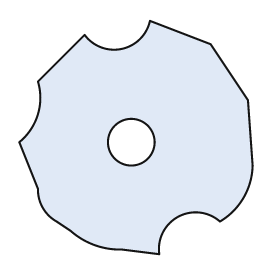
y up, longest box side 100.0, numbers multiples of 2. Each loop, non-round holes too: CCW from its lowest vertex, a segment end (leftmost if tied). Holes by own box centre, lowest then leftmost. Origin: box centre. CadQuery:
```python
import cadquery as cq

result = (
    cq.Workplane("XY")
    .moveTo(10.0, -50.0)
    .threePointArc((18.0, -34.0), (36.0, -36.0))
    .threePointArc((46.0, -26.0), (50.0, -12.0))
    .lineTo(48.0, 16.0)
    .lineTo(32.0, 40.0)
    .lineTo(6.0, 50.0)
    .threePointArc((-6.0, 38.0), (-22.0, 44.0))
    .lineTo(-42.0, 24.0)
    .threePointArc((-42.0, 10.0), (-50.0, -2.0))
    .lineTo(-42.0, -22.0)
    .threePointArc((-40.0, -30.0), (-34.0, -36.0))
    .lineTo(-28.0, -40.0)
    .threePointArc((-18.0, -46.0), (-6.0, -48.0))
    .close()
    .moveTo(-2.0, -2.0)
    .circle(10.0)
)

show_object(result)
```